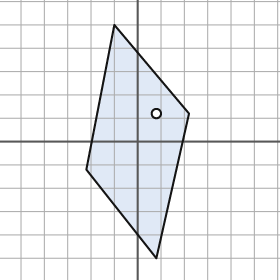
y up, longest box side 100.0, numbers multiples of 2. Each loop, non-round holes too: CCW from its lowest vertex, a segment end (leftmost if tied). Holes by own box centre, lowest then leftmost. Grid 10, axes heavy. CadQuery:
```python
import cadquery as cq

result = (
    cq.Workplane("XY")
    .moveTo(8.0, -50.0)
    .lineTo(22.0, 12.0)
    .lineTo(-10.0, 50.0)
    .lineTo(-22.0, -12.0)
    .close()
    .moveTo(8.0, 12.0)
    .circle(2.0)
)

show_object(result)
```